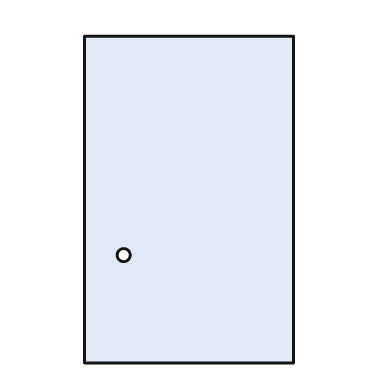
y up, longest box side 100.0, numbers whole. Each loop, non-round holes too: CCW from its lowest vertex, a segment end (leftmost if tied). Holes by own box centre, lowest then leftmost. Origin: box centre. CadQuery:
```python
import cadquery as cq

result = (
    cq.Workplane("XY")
    .moveTo(-32.0, -50.0)
    .lineTo(32.0, -50.0)
    .lineTo(32.0, 50.0)
    .lineTo(-32.0, 50.0)
    .close()
    .moveTo(-20.0, -17.0)
    .circle(2.0)
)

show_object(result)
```